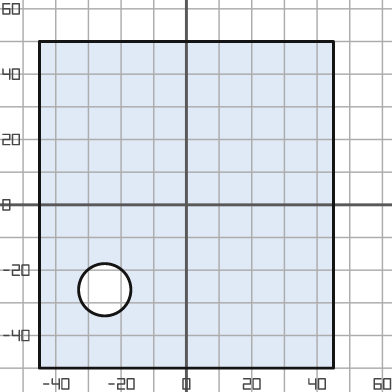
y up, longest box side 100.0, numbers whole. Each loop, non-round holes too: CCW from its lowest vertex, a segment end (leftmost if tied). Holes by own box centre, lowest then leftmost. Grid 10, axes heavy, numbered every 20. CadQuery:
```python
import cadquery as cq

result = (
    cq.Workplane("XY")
    .moveTo(-45.0, -50.0)
    .lineTo(45.0, -50.0)
    .lineTo(45.0, 50.0)
    .lineTo(-45.0, 50.0)
    .close()
    .moveTo(-25.0, -26.0)
    .circle(8.0)
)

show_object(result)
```